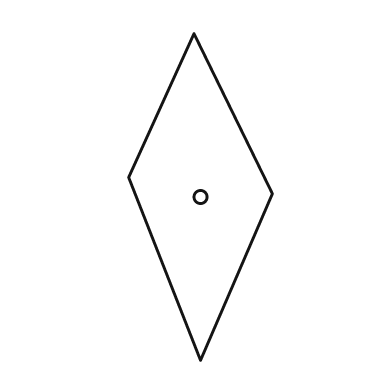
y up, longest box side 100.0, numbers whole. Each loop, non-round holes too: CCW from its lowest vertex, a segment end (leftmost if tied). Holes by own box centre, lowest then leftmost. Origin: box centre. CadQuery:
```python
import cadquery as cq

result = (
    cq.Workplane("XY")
    .moveTo(0.0, -50.0)
    .lineTo(22.0, 1.0)
    .lineTo(-2.0, 50.0)
    .lineTo(-22.0, 6.0)
    .close()
    .moveTo(0.0, 0.0)
    .circle(2.0)
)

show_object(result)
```